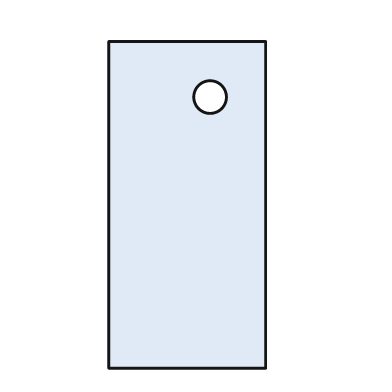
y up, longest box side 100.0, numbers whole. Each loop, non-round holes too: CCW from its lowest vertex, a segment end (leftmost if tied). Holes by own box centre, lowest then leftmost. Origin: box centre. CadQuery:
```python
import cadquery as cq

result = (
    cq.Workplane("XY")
    .moveTo(-24.0, -50.0)
    .lineTo(24.0, -50.0)
    .lineTo(24.0, 50.0)
    .lineTo(-24.0, 50.0)
    .close()
    .moveTo(7.0, 33.0)
    .circle(5.0)
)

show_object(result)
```